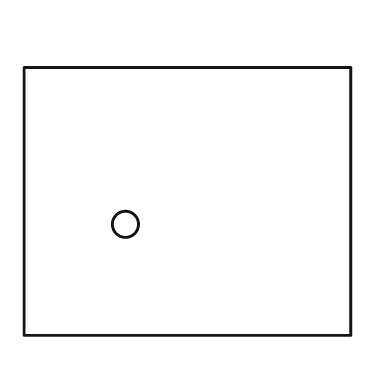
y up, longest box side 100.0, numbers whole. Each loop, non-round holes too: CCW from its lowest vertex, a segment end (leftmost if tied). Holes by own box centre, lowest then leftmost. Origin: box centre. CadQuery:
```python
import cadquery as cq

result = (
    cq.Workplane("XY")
    .moveTo(-50.0, -41.0)
    .lineTo(50.0, -41.0)
    .lineTo(50.0, 41.0)
    .lineTo(-50.0, 41.0)
    .close()
    .moveTo(-19.0, -7.0)
    .circle(4.0)
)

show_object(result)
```